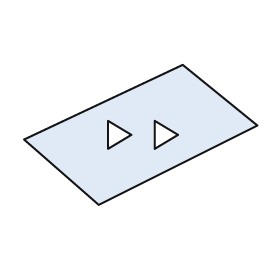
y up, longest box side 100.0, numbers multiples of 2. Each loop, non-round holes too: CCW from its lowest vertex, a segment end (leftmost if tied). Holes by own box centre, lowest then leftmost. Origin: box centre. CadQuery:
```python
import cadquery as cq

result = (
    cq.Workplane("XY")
    .moveTo(-18.0, -30.0)
    .lineTo(50.0, 4.0)
    .lineTo(18.0, 30.0)
    .lineTo(-50.0, -2.0)
    .close()
    .moveTo(-14.0, -6.0)
    .lineTo(-4.0, 0.0)
    .lineTo(-14.0, 6.0)
    .close()
    .moveTo(6.0, -6.0)
    .lineTo(16.0, 0.0)
    .lineTo(6.0, 6.0)
    .close()
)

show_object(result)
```